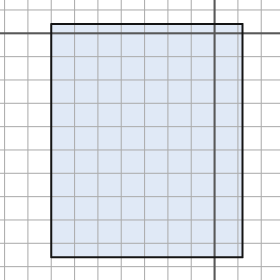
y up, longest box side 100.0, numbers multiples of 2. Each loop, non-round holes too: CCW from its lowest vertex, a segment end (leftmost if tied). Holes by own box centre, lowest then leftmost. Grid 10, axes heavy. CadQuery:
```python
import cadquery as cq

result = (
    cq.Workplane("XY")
    .moveTo(-70.0, -96.0)
    .lineTo(12.0, -96.0)
    .lineTo(12.0, 4.0)
    .lineTo(-70.0, 4.0)
    .close()
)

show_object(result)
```